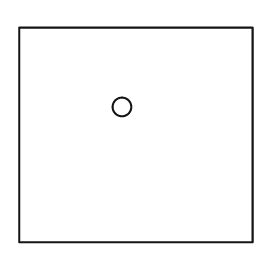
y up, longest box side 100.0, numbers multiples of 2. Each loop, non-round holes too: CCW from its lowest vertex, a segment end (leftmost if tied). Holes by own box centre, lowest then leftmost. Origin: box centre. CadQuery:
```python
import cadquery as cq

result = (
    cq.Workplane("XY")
    .moveTo(-50.0, -46.0)
    .lineTo(50.0, -46.0)
    .lineTo(50.0, 46.0)
    .lineTo(-50.0, 46.0)
    .close()
    .moveTo(-6.0, 12.0)
    .circle(4.0)
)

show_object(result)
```